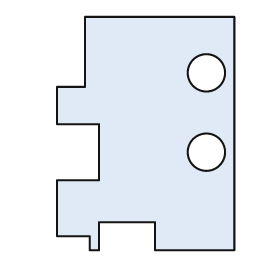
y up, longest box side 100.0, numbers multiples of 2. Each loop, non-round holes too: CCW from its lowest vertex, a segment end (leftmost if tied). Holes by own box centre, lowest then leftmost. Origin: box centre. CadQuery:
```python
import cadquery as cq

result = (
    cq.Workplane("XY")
    .moveTo(-24.0, -50.0)
    .lineTo(-20.0, -50.0)
    .lineTo(-20.0, -38.0)
    .lineTo(4.0, -38.0)
    .lineTo(4.0, -50.0)
    .lineTo(38.0, -50.0)
    .lineTo(38.0, 50.0)
    .lineTo(-26.0, 50.0)
    .lineTo(-26.0, 20.0)
    .lineTo(-38.0, 20.0)
    .lineTo(-38.0, 4.0)
    .lineTo(-20.0, 4.0)
    .lineTo(-20.0, -20.0)
    .lineTo(-38.0, -20.0)
    .lineTo(-38.0, -44.0)
    .lineTo(-24.0, -44.0)
    .close()
    .moveTo(26.0, -8.0)
    .circle(8.0)
    .moveTo(26.0, 26.0)
    .circle(8.0)
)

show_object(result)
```